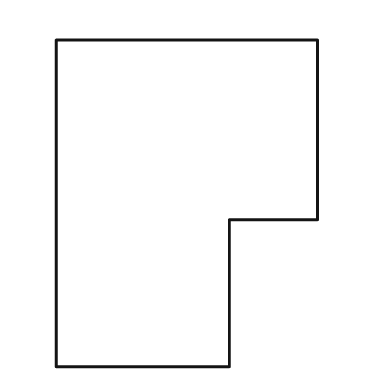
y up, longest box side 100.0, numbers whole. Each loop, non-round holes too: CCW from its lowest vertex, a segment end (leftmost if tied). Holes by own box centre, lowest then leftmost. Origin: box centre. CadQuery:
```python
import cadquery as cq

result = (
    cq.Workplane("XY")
    .moveTo(-40.0, -50.0)
    .lineTo(13.0, -50.0)
    .lineTo(13.0, -5.0)
    .lineTo(40.0, -5.0)
    .lineTo(40.0, 50.0)
    .lineTo(-40.0, 50.0)
    .close()
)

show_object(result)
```